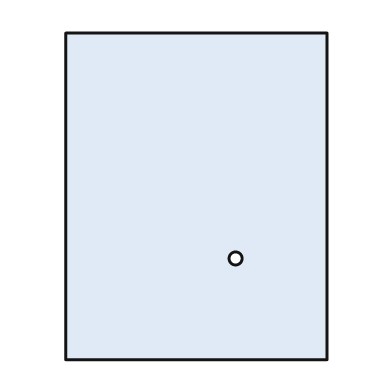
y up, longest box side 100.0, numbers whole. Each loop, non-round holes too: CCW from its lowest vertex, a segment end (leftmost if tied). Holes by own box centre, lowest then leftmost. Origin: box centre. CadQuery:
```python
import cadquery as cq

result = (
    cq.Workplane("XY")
    .moveTo(-40.0, -50.0)
    .lineTo(40.0, -50.0)
    .lineTo(40.0, 50.0)
    .lineTo(-40.0, 50.0)
    .close()
    .moveTo(12.0, -19.0)
    .circle(2.0)
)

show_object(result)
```